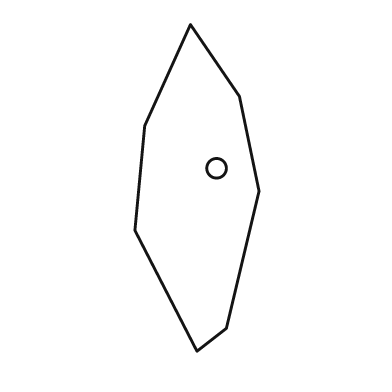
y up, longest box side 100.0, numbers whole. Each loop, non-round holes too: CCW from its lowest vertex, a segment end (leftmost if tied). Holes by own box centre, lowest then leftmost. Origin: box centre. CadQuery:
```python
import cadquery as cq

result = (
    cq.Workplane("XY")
    .moveTo(0.0, -50.0)
    .lineTo(9.0, -43.0)
    .lineTo(19.0, -1.0)
    .lineTo(13.0, 28.0)
    .lineTo(-2.0, 50.0)
    .lineTo(-16.0, 19.0)
    .lineTo(-19.0, -13.0)
    .close()
    .moveTo(6.0, 6.0)
    .circle(3.0)
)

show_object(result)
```